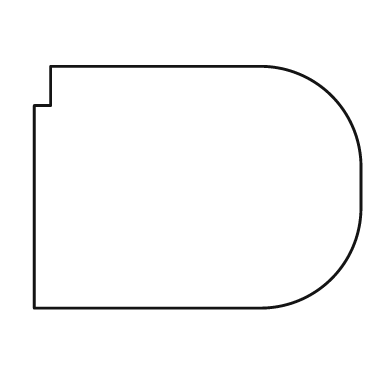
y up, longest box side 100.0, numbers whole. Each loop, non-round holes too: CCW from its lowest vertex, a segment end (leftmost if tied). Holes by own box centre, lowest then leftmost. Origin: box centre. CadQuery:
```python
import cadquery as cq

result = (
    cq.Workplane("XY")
    .moveTo(-50.0, -37.0)
    .lineTo(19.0, -37.0)
    .threePointArc((41.0, -28.0), (50.0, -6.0))
    .lineTo(50.0, 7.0)
    .threePointArc((41.0, 28.0), (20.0, 37.0))
    .lineTo(-45.0, 37.0)
    .lineTo(-45.0, 25.0)
    .lineTo(-50.0, 25.0)
    .close()
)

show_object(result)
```